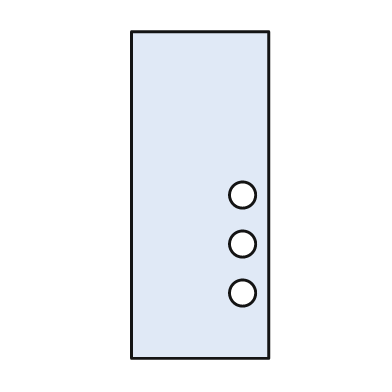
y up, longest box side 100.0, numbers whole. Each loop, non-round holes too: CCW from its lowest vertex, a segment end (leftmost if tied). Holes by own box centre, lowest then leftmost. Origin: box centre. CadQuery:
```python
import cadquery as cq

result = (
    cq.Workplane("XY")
    .moveTo(-21.0, -50.0)
    .lineTo(21.0, -50.0)
    .lineTo(21.0, 50.0)
    .lineTo(-21.0, 50.0)
    .close()
    .moveTo(13.0, -30.0)
    .circle(4.0)
    .moveTo(13.0, -15.0)
    .circle(4.0)
    .moveTo(13.0, 0.0)
    .circle(4.0)
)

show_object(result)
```